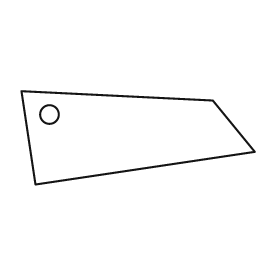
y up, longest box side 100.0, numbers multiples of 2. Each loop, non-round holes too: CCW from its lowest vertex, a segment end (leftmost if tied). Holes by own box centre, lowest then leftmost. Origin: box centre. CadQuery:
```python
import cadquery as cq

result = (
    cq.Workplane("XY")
    .moveTo(-44.0, -20.0)
    .lineTo(50.0, -6.0)
    .lineTo(32.0, 16.0)
    .lineTo(-50.0, 20.0)
    .close()
    .moveTo(-38.0, 10.0)
    .circle(4.0)
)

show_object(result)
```